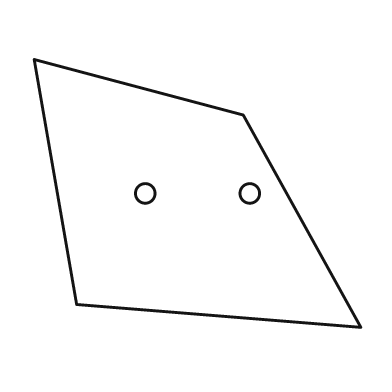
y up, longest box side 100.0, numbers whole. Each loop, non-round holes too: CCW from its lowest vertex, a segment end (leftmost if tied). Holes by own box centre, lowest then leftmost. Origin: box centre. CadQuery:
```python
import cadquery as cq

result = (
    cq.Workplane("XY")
    .moveTo(50.0, -41.0)
    .lineTo(14.0, 24.0)
    .lineTo(-50.0, 41.0)
    .lineTo(-37.0, -34.0)
    .close()
    .moveTo(-16.0, 0.0)
    .circle(3.0)
    .moveTo(16.0, 0.0)
    .circle(3.0)
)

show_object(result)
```